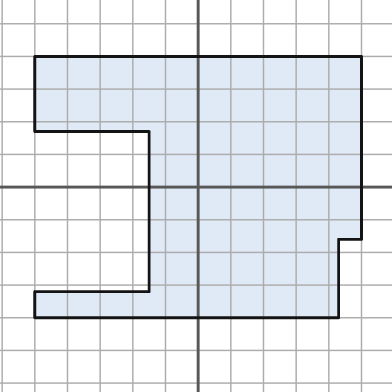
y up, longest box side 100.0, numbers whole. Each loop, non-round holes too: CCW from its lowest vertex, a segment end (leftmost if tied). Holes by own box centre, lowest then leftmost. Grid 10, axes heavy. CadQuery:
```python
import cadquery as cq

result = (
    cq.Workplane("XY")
    .moveTo(-50.0, -40.0)
    .lineTo(43.0, -40.0)
    .lineTo(43.0, -16.0)
    .lineTo(50.0, -16.0)
    .lineTo(50.0, 40.0)
    .lineTo(-50.0, 40.0)
    .lineTo(-50.0, 17.0)
    .lineTo(-15.0, 17.0)
    .lineTo(-15.0, -32.0)
    .lineTo(-50.0, -32.0)
    .close()
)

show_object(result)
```